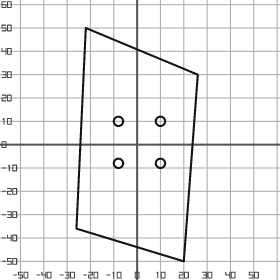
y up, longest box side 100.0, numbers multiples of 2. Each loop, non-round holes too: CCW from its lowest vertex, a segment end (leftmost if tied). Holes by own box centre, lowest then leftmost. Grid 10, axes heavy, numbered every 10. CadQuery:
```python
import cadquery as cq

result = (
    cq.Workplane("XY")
    .moveTo(20.0, -50.0)
    .lineTo(26.0, 30.0)
    .lineTo(-22.0, 50.0)
    .lineTo(-26.0, -36.0)
    .close()
    .moveTo(-8.0, -8.0)
    .circle(2.0)
    .moveTo(10.0, -8.0)
    .circle(2.0)
    .moveTo(-8.0, 10.0)
    .circle(2.0)
    .moveTo(10.0, 10.0)
    .circle(2.0)
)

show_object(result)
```